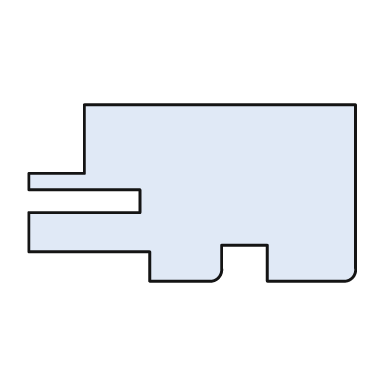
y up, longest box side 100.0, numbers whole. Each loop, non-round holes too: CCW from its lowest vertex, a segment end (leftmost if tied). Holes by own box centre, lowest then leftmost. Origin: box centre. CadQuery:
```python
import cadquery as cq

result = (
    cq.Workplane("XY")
    .moveTo(-13.0, -27.0)
    .lineTo(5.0, -27.0)
    .threePointArc((8.0, -26.0), (9.0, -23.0))
    .lineTo(9.0, -16.0)
    .lineTo(23.0, -16.0)
    .lineTo(23.0, -27.0)
    .lineTo(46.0, -27.0)
    .threePointArc((49.0, -26.0), (50.0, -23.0))
    .lineTo(50.0, 27.0)
    .lineTo(-33.0, 27.0)
    .lineTo(-33.0, 6.0)
    .lineTo(-50.0, 6.0)
    .lineTo(-50.0, 1.0)
    .lineTo(-16.0, 1.0)
    .lineTo(-16.0, -6.0)
    .lineTo(-50.0, -6.0)
    .lineTo(-50.0, -18.0)
    .lineTo(-13.0, -18.0)
    .close()
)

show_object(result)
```